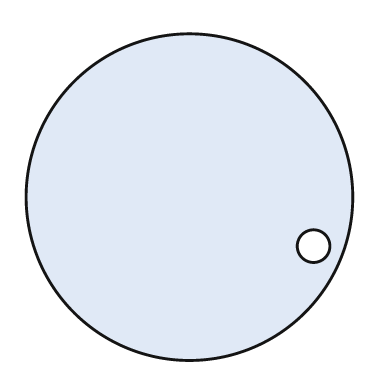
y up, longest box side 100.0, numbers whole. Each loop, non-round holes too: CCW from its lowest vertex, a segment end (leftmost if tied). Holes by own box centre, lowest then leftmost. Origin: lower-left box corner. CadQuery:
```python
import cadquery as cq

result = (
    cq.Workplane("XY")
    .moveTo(50.0, 50.0)
    .circle(50.0)
    .moveTo(88.0, 35.0)
    .circle(5.0)
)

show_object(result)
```